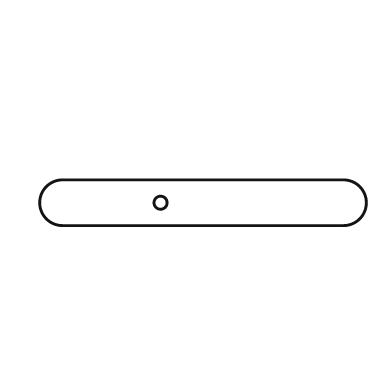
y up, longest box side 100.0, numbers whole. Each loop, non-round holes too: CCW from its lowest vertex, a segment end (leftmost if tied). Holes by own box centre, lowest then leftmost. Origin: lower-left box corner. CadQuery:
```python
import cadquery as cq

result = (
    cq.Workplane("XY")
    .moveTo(7.0, 0.0)
    .lineTo(93.0, 0.0)
    .threePointArc((100.0, 7.0), (93.0, 14.0))
    .lineTo(7.0, 14.0)
    .threePointArc((0.0, 7.0), (7.0, 0.0))
    .close()
    .moveTo(37.0, 7.0)
    .circle(2.0)
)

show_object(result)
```